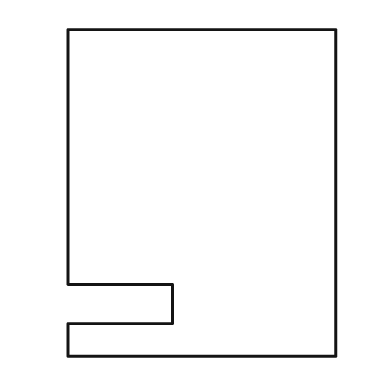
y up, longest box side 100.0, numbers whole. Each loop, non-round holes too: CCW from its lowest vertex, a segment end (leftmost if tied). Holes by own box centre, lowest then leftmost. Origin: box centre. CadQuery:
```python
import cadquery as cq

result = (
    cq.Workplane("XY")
    .moveTo(-41.0, -50.0)
    .lineTo(41.0, -50.0)
    .lineTo(41.0, 50.0)
    .lineTo(-41.0, 50.0)
    .lineTo(-41.0, -28.0)
    .lineTo(-9.0, -28.0)
    .lineTo(-9.0, -40.0)
    .lineTo(-41.0, -40.0)
    .close()
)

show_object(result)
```